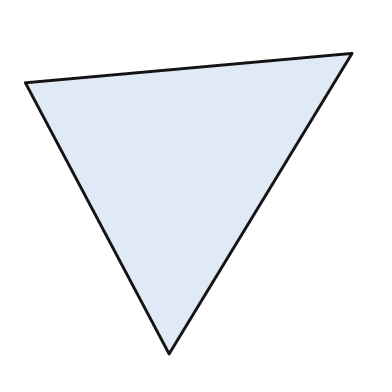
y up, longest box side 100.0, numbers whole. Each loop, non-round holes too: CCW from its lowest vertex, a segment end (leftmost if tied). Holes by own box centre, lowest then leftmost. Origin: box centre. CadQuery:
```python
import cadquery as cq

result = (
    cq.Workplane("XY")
    .moveTo(-6.0, -46.0)
    .lineTo(50.0, 46.0)
    .lineTo(-50.0, 37.0)
    .close()
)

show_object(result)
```